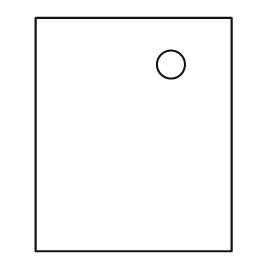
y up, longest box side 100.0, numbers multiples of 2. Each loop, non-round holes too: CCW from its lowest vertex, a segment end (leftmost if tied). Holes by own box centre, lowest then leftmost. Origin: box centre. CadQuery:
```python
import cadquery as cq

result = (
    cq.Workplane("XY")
    .moveTo(-42.0, -50.0)
    .lineTo(42.0, -50.0)
    .lineTo(42.0, 50.0)
    .lineTo(-42.0, 50.0)
    .close()
    .moveTo(16.0, 30.0)
    .circle(6.0)
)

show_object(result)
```